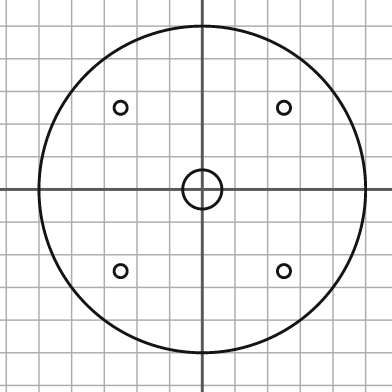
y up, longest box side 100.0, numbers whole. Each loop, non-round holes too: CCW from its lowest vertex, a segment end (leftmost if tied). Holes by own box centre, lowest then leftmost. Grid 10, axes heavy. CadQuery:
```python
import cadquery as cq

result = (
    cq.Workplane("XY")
    .moveTo(0.0, 0.0)
    .circle(50.0)
    .moveTo(-25.0, -25.0)
    .circle(2.0)
    .moveTo(25.0, -25.0)
    .circle(2.0)
    .moveTo(0.0, 0.0)
    .circle(6.0)
    .moveTo(-25.0, 25.0)
    .circle(2.0)
    .moveTo(25.0, 25.0)
    .circle(2.0)
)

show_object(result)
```